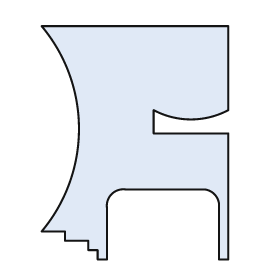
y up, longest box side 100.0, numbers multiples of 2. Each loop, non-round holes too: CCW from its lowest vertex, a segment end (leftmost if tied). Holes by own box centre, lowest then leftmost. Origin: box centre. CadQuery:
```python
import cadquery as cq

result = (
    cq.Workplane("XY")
    .moveTo(-16.0, -50.0)
    .lineTo(-12.0, -50.0)
    .lineTo(-12.0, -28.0)
    .threePointArc((-10.0, -22.0), (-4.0, -20.0))
    .lineTo(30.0, -20.0)
    .threePointArc((34.0, -22.0), (36.0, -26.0))
    .lineTo(36.0, -50.0)
    .lineTo(40.0, -50.0)
    .lineTo(40.0, 4.0)
    .lineTo(8.0, 4.0)
    .lineTo(8.0, 14.0)
    .threePointArc((24.0, 10.0), (40.0, 14.0))
    .lineTo(40.0, 50.0)
    .lineTo(-40.0, 50.0)
    .threePointArc((-24.0, 6.0), (-40.0, -38.0))
    .lineTo(-30.0, -38.0)
    .lineTo(-30.0, -42.0)
    .lineTo(-20.0, -42.0)
    .lineTo(-20.0, -46.0)
    .lineTo(-16.0, -46.0)
    .close()
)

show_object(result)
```